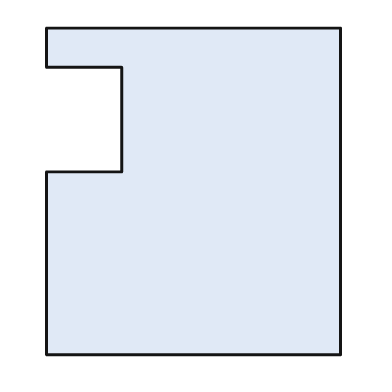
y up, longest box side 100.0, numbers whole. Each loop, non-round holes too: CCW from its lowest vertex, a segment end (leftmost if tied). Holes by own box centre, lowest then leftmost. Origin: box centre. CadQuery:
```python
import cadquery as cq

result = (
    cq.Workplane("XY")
    .moveTo(-45.0, -50.0)
    .lineTo(45.0, -50.0)
    .lineTo(45.0, 50.0)
    .lineTo(-45.0, 50.0)
    .lineTo(-45.0, 38.0)
    .lineTo(-22.0, 38.0)
    .lineTo(-22.0, 6.0)
    .lineTo(-45.0, 6.0)
    .close()
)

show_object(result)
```